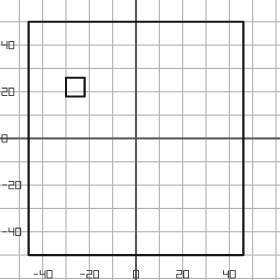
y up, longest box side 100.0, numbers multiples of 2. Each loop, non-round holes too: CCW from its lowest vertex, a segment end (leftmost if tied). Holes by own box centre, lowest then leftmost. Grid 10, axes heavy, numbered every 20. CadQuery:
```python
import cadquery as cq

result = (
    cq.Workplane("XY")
    .moveTo(-46.0, -50.0)
    .lineTo(46.0, -50.0)
    .lineTo(46.0, 50.0)
    .lineTo(-46.0, 50.0)
    .close()
    .moveTo(-30.0, 18.0)
    .lineTo(-22.0, 18.0)
    .lineTo(-22.0, 26.0)
    .lineTo(-30.0, 26.0)
    .close()
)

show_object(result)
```